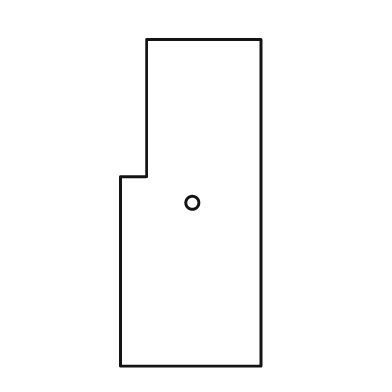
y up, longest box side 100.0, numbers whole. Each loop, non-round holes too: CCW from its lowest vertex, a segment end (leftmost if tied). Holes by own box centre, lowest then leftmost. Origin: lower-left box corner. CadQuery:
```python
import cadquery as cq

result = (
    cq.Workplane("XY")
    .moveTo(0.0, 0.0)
    .lineTo(43.0, 0.0)
    .lineTo(43.0, 100.0)
    .lineTo(8.0, 100.0)
    .lineTo(8.0, 58.0)
    .lineTo(0.0, 58.0)
    .close()
    .moveTo(22.0, 50.0)
    .circle(2.0)
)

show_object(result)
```